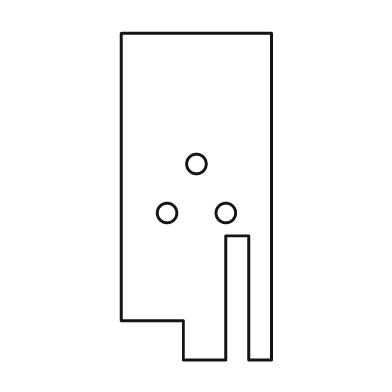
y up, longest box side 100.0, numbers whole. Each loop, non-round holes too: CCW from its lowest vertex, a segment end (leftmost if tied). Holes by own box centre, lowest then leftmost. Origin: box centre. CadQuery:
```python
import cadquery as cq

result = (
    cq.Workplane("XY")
    .moveTo(-4.0, -50.0)
    .lineTo(9.0, -50.0)
    .lineTo(9.0, -12.0)
    .lineTo(16.0, -12.0)
    .lineTo(16.0, -50.0)
    .lineTo(23.0, -50.0)
    .lineTo(23.0, 50.0)
    .lineTo(-23.0, 50.0)
    .lineTo(-23.0, -38.0)
    .lineTo(-4.0, -38.0)
    .close()
    .moveTo(-9.0, -5.0)
    .circle(3.0)
    .moveTo(9.0, -5.0)
    .circle(3.0)
    .moveTo(0.0, 10.0)
    .circle(3.0)
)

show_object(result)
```